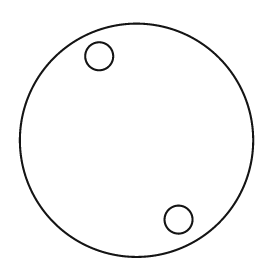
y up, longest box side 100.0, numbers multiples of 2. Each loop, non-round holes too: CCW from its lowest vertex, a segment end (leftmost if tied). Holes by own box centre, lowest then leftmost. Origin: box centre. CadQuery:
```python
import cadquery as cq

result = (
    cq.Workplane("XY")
    .moveTo(0.0, 0.0)
    .circle(50.0)
    .moveTo(18.0, -34.0)
    .circle(6.0)
    .moveTo(-16.0, 36.0)
    .circle(6.0)
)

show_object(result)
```